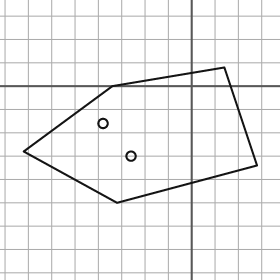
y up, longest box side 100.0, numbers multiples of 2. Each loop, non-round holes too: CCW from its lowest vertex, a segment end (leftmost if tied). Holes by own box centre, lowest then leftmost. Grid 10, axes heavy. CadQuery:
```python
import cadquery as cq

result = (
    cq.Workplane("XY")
    .moveTo(-32.0, -50.0)
    .lineTo(28.0, -34.0)
    .lineTo(14.0, 8.0)
    .lineTo(-34.0, 0.0)
    .lineTo(-72.0, -28.0)
    .close()
    .moveTo(-26.0, -30.0)
    .circle(2.0)
    .moveTo(-38.0, -16.0)
    .circle(2.0)
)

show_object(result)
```